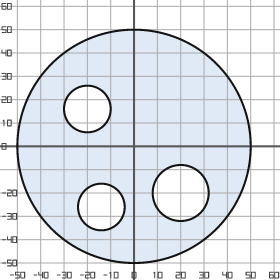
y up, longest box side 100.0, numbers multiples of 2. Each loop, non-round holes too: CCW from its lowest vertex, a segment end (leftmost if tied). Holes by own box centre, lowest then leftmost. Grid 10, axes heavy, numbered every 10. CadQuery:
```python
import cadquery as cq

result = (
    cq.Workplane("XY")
    .moveTo(0.0, 0.0)
    .circle(50.0)
    .moveTo(-14.0, -26.0)
    .circle(10.0)
    .moveTo(20.0, -20.0)
    .circle(12.0)
    .moveTo(-20.0, 16.0)
    .circle(10.0)
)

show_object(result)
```